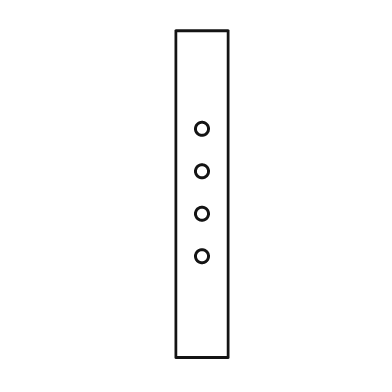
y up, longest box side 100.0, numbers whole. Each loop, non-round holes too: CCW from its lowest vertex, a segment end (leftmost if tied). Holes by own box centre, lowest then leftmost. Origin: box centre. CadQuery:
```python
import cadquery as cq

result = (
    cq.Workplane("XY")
    .moveTo(-8.0, -50.0)
    .lineTo(8.0, -50.0)
    .lineTo(8.0, 50.0)
    .lineTo(-8.0, 50.0)
    .close()
    .moveTo(0.0, -19.0)
    .circle(2.0)
    .moveTo(0.0, -6.0)
    .circle(2.0)
    .moveTo(0.0, 7.0)
    .circle(2.0)
    .moveTo(0.0, 20.0)
    .circle(2.0)
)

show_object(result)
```